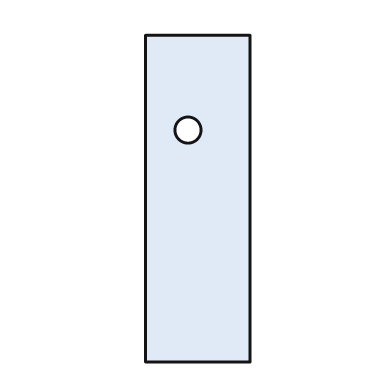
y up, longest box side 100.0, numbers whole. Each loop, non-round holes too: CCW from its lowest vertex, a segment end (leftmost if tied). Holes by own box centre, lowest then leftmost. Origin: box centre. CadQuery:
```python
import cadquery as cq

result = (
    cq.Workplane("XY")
    .moveTo(-16.0, -50.0)
    .lineTo(16.0, -50.0)
    .lineTo(16.0, 50.0)
    .lineTo(-16.0, 50.0)
    .close()
    .moveTo(-3.0, 21.0)
    .circle(4.0)
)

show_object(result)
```